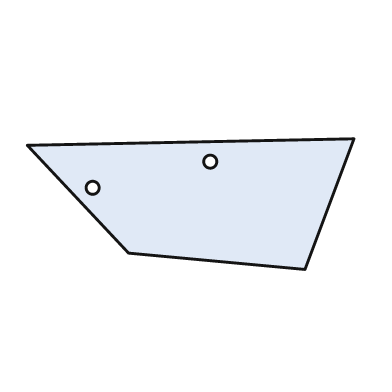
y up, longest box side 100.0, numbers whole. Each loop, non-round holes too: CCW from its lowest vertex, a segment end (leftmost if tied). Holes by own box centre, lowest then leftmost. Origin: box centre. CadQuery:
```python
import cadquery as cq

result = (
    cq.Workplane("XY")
    .moveTo(35.0, -20.0)
    .lineTo(50.0, 20.0)
    .lineTo(-50.0, 18.0)
    .lineTo(-19.0, -15.0)
    .close()
    .moveTo(-30.0, 5.0)
    .circle(2.0)
    .moveTo(6.0, 13.0)
    .circle(2.0)
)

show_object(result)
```